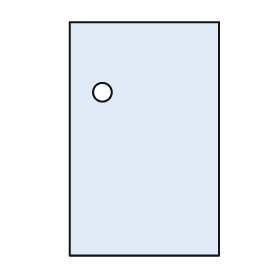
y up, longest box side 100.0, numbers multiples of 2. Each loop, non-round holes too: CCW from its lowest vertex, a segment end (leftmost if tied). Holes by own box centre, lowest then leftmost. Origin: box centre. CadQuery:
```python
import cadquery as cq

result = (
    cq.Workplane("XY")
    .moveTo(-32.0, -50.0)
    .lineTo(32.0, -50.0)
    .lineTo(32.0, 50.0)
    .lineTo(-32.0, 50.0)
    .close()
    .moveTo(-18.0, 20.0)
    .circle(4.0)
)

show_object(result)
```